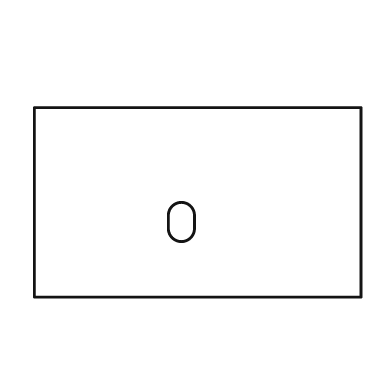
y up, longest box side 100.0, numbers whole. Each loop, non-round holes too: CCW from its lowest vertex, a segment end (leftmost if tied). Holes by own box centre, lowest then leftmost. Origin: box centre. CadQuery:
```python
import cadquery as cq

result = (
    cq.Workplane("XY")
    .moveTo(-50.0, -29.0)
    .lineTo(50.0, -29.0)
    .lineTo(50.0, 29.0)
    .lineTo(-50.0, 29.0)
    .close()
    .moveTo(-9.0, -8.0)
    .threePointArc((-5.0, -12.0), (-1.0, -8.0))
    .lineTo(-1.0, -4.0)
    .threePointArc((-5.0, 0.0), (-9.0, -4.0))
    .close()
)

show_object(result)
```